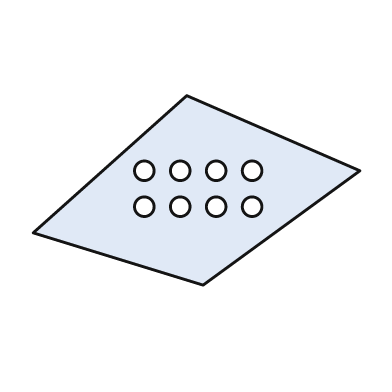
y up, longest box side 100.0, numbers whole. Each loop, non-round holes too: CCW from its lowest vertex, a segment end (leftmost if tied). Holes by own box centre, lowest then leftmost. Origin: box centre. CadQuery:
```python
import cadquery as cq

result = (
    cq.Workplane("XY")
    .moveTo(2.0, -29.0)
    .lineTo(50.0, 6.0)
    .lineTo(-3.0, 29.0)
    .lineTo(-50.0, -13.0)
    .close()
    .moveTo(-16.0, -5.0)
    .circle(3.0)
    .moveTo(-5.0, -5.0)
    .circle(3.0)
    .moveTo(6.0, -5.0)
    .circle(3.0)
    .moveTo(17.0, -5.0)
    .circle(3.0)
    .moveTo(-16.0, 6.0)
    .circle(3.0)
    .moveTo(-5.0, 6.0)
    .circle(3.0)
    .moveTo(6.0, 6.0)
    .circle(3.0)
    .moveTo(17.0, 6.0)
    .circle(3.0)
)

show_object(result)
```